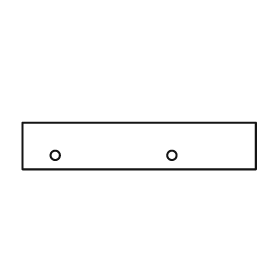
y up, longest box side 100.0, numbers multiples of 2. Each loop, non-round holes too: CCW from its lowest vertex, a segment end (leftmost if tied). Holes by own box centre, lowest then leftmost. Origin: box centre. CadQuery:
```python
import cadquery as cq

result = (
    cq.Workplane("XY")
    .moveTo(-50.0, -10.0)
    .lineTo(50.0, -10.0)
    .lineTo(50.0, 10.0)
    .lineTo(-50.0, 10.0)
    .close()
    .moveTo(-36.0, -4.0)
    .circle(2.0)
    .moveTo(14.0, -4.0)
    .circle(2.0)
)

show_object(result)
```